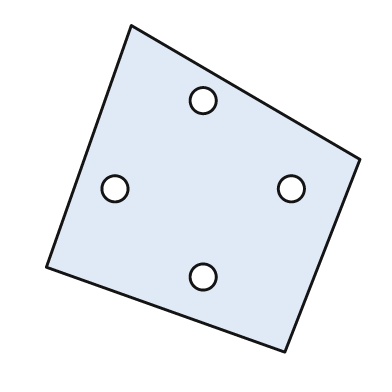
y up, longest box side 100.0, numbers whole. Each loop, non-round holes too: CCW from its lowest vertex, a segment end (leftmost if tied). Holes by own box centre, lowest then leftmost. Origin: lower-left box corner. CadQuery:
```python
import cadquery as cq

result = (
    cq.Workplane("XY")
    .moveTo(73.0, 0.0)
    .lineTo(96.0, 59.0)
    .lineTo(26.0, 100.0)
    .lineTo(0.0, 26.0)
    .close()
    .moveTo(48.0, 23.0)
    .circle(4.0)
    .moveTo(21.0, 50.0)
    .circle(4.0)
    .moveTo(75.0, 50.0)
    .circle(4.0)
    .moveTo(48.0, 77.0)
    .circle(4.0)
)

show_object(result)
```